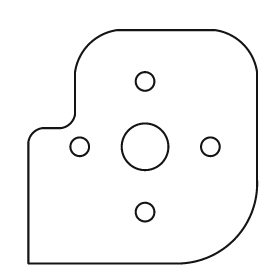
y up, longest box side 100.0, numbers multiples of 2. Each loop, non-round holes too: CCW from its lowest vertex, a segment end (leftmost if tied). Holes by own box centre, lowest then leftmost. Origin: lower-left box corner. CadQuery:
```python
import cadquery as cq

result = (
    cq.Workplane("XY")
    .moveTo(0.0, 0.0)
    .lineTo(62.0, 0.0)
    .threePointArc((88.0, 10.0), (98.0, 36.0))
    .lineTo(98.0, 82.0)
    .threePointArc((92.0, 94.0), (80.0, 100.0))
    .lineTo(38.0, 100.0)
    .threePointArc((26.0, 94.0), (20.0, 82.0))
    .lineTo(20.0, 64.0)
    .threePointArc((18.0, 60.0), (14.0, 58.0))
    .lineTo(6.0, 58.0)
    .threePointArc((2.0, 56.0), (0.0, 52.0))
    .close()
    .moveTo(50.0, 22.0)
    .circle(4.0)
    .moveTo(22.0, 50.0)
    .circle(4.0)
    .moveTo(50.0, 50.0)
    .circle(10.0)
    .moveTo(78.0, 50.0)
    .circle(4.0)
    .moveTo(50.0, 78.0)
    .circle(4.0)
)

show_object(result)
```